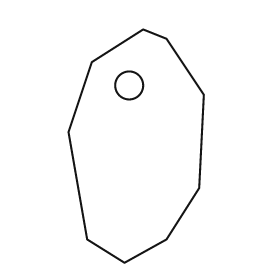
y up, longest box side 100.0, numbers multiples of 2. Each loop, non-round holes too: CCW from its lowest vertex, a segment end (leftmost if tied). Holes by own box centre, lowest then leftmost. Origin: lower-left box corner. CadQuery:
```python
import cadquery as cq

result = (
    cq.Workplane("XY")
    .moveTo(24.0, 0.0)
    .lineTo(42.0, 10.0)
    .lineTo(56.0, 32.0)
    .lineTo(58.0, 72.0)
    .lineTo(42.0, 96.0)
    .lineTo(32.0, 100.0)
    .lineTo(10.0, 86.0)
    .lineTo(0.0, 56.0)
    .lineTo(8.0, 10.0)
    .close()
    .moveTo(26.0, 76.0)
    .circle(6.0)
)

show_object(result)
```